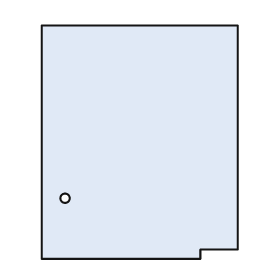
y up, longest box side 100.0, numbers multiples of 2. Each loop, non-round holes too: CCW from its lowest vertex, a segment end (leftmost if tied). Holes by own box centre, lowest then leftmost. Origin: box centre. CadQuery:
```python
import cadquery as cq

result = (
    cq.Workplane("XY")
    .moveTo(-42.0, -50.0)
    .lineTo(26.0, -50.0)
    .lineTo(26.0, -46.0)
    .lineTo(42.0, -46.0)
    .lineTo(42.0, 50.0)
    .lineTo(-42.0, 50.0)
    .close()
    .moveTo(-32.0, -24.0)
    .circle(2.0)
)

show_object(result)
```